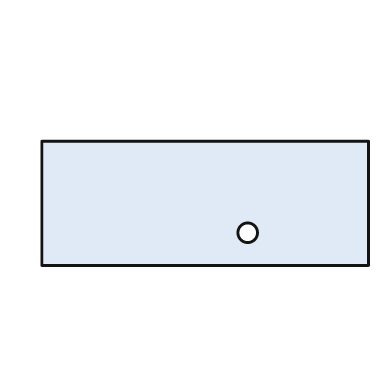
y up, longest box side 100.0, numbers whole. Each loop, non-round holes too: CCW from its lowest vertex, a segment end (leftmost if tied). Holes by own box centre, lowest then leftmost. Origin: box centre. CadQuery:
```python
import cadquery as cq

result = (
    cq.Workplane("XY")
    .moveTo(-50.0, -19.0)
    .lineTo(50.0, -19.0)
    .lineTo(50.0, 19.0)
    .lineTo(-50.0, 19.0)
    .close()
    .moveTo(13.0, -9.0)
    .circle(3.0)
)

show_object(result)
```